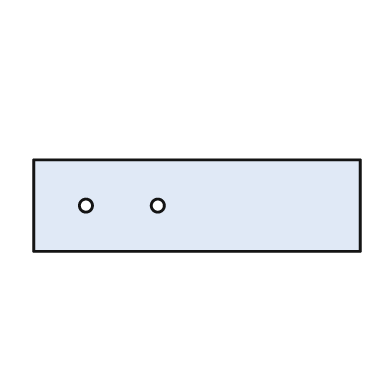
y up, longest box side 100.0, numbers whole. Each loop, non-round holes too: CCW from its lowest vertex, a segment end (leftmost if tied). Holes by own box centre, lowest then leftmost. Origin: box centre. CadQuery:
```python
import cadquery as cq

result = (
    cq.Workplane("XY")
    .moveTo(-50.0, -14.0)
    .lineTo(50.0, -14.0)
    .lineTo(50.0, 14.0)
    .lineTo(-50.0, 14.0)
    .close()
    .moveTo(-34.0, 0.0)
    .circle(2.0)
    .moveTo(-12.0, 0.0)
    .circle(2.0)
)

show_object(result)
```